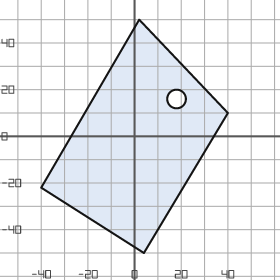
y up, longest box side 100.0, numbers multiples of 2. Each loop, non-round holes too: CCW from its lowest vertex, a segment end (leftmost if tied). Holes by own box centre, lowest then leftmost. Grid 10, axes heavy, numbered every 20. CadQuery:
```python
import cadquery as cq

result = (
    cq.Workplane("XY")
    .moveTo(4.0, -50.0)
    .lineTo(40.0, 10.0)
    .lineTo(2.0, 50.0)
    .lineTo(-40.0, -22.0)
    .close()
    .moveTo(18.0, 16.0)
    .circle(4.0)
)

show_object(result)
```